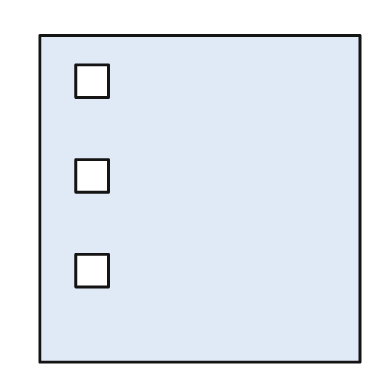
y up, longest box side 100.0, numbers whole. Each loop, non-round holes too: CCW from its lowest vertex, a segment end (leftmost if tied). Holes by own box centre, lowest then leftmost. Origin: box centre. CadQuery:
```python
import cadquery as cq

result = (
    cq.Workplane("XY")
    .moveTo(-49.0, -50.0)
    .lineTo(49.0, -50.0)
    .lineTo(49.0, 50.0)
    .lineTo(-49.0, 50.0)
    .close()
    .moveTo(-38.0, -27.0)
    .lineTo(-28.0, -27.0)
    .lineTo(-28.0, -17.0)
    .lineTo(-38.0, -17.0)
    .close()
    .moveTo(-38.0, 2.0)
    .lineTo(-28.0, 2.0)
    .lineTo(-28.0, 12.0)
    .lineTo(-38.0, 12.0)
    .close()
    .moveTo(-38.0, 31.0)
    .lineTo(-28.0, 31.0)
    .lineTo(-28.0, 41.0)
    .lineTo(-38.0, 41.0)
    .close()
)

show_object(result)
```